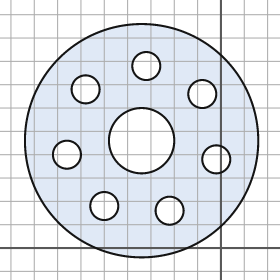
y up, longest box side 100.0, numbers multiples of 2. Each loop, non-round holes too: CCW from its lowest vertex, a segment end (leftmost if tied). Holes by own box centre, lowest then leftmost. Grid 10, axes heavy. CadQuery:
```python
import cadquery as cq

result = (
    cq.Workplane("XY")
    .moveTo(-34.0, 46.0)
    .circle(50.0)
    .moveTo(-22.0, 16.0)
    .circle(6.0)
    .moveTo(-50.0, 18.0)
    .circle(6.0)
    .moveTo(-2.0, 38.0)
    .circle(6.0)
    .moveTo(-66.0, 40.0)
    .circle(6.0)
    .moveTo(-34.0, 46.0)
    .circle(14.0)
    .moveTo(-8.0, 66.0)
    .circle(6.0)
    .moveTo(-58.0, 68.0)
    .circle(6.0)
    .moveTo(-32.0, 78.0)
    .circle(6.0)
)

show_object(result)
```